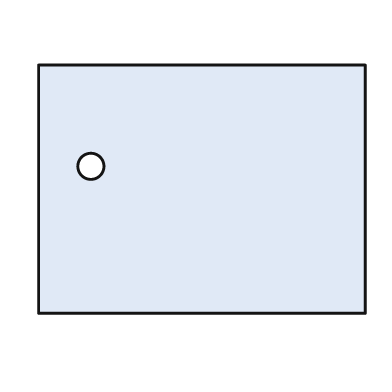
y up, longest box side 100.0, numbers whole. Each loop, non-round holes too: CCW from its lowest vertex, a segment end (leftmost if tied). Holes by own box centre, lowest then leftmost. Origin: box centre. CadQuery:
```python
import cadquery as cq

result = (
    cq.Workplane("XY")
    .moveTo(-50.0, -38.0)
    .lineTo(50.0, -38.0)
    .lineTo(50.0, 38.0)
    .lineTo(-50.0, 38.0)
    .close()
    .moveTo(-34.0, 7.0)
    .circle(4.0)
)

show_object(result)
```